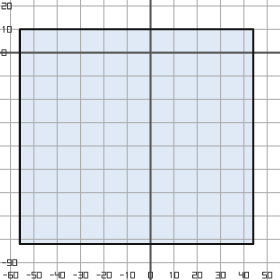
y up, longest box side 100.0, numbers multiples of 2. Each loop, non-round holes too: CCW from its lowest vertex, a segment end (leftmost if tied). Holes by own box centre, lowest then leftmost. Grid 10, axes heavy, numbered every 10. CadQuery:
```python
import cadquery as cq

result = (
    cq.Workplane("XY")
    .moveTo(-56.0, -82.0)
    .lineTo(44.0, -82.0)
    .lineTo(44.0, 10.0)
    .lineTo(-56.0, 10.0)
    .close()
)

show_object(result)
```